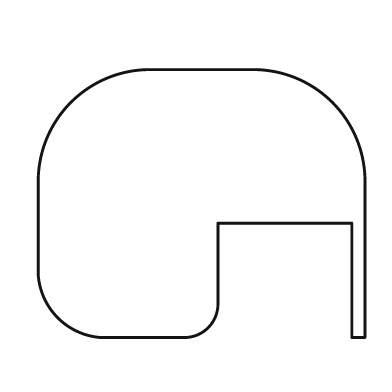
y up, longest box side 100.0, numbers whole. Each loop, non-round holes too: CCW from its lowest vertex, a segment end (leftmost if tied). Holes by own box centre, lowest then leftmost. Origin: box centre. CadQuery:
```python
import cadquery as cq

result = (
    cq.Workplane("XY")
    .moveTo(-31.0, -41.0)
    .lineTo(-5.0, -41.0)
    .threePointArc((2.0, -38.0), (5.0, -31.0))
    .lineTo(5.0, -6.0)
    .lineTo(46.0, -6.0)
    .lineTo(46.0, -41.0)
    .lineTo(50.0, -41.0)
    .lineTo(50.0, 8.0)
    .threePointArc((40.0, 31.0), (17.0, 41.0))
    .lineTo(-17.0, 41.0)
    .threePointArc((-40.0, 31.0), (-50.0, 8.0))
    .lineTo(-50.0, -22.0)
    .threePointArc((-44.0, -35.0), (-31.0, -41.0))
    .close()
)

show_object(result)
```